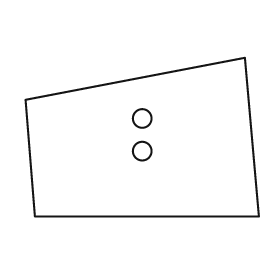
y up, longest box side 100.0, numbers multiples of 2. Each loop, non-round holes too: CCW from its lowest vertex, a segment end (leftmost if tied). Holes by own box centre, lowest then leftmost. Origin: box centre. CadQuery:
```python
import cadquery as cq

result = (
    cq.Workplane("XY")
    .moveTo(-46.0, -34.0)
    .lineTo(50.0, -34.0)
    .lineTo(44.0, 34.0)
    .lineTo(-50.0, 16.0)
    .close()
    .moveTo(0.0, -6.0)
    .circle(4.0)
    .moveTo(0.0, 8.0)
    .circle(4.0)
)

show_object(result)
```